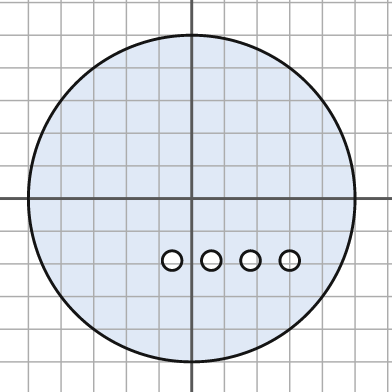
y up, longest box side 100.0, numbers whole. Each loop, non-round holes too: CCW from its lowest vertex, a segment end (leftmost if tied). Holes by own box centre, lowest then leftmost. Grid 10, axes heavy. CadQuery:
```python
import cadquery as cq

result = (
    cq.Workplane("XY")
    .moveTo(0.0, 0.0)
    .circle(50.0)
    .moveTo(-6.0, -19.0)
    .circle(3.0)
    .moveTo(6.0, -19.0)
    .circle(3.0)
    .moveTo(18.0, -19.0)
    .circle(3.0)
    .moveTo(30.0, -19.0)
    .circle(3.0)
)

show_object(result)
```